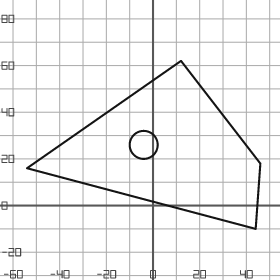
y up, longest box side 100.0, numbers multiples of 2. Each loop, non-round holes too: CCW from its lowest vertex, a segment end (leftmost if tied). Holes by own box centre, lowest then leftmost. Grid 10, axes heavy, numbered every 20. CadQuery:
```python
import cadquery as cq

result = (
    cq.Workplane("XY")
    .moveTo(44.0, -10.0)
    .lineTo(46.0, 18.0)
    .lineTo(12.0, 62.0)
    .lineTo(-54.0, 16.0)
    .close()
    .moveTo(-4.0, 26.0)
    .circle(6.0)
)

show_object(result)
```